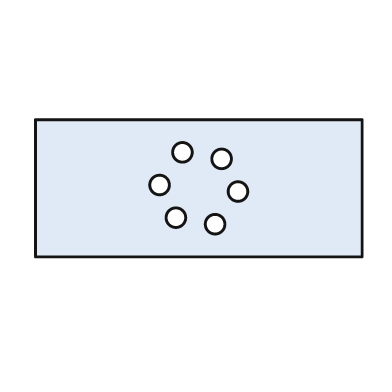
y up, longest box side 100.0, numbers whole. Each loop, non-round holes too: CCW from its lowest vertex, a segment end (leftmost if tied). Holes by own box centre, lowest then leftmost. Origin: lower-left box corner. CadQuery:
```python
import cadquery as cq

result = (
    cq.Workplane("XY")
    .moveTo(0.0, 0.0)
    .lineTo(100.0, 0.0)
    .lineTo(100.0, 42.0)
    .lineTo(0.0, 42.0)
    .close()
    .moveTo(55.0, 10.0)
    .circle(3.0)
    .moveTo(43.0, 12.0)
    .circle(3.0)
    .moveTo(62.0, 20.0)
    .circle(3.0)
    .moveTo(38.0, 22.0)
    .circle(3.0)
    .moveTo(57.0, 30.0)
    .circle(3.0)
    .moveTo(45.0, 32.0)
    .circle(3.0)
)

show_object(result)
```